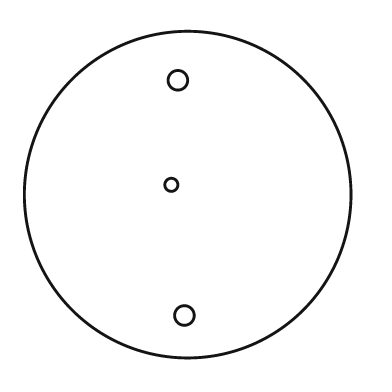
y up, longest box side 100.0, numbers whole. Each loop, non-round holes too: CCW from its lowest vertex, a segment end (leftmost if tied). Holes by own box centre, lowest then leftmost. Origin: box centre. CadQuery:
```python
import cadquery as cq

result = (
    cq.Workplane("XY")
    .moveTo(0.0, 0.0)
    .circle(50.0)
    .moveTo(-1.0, -37.0)
    .circle(3.0)
    .moveTo(-5.0, 3.0)
    .circle(2.0)
    .moveTo(-3.0, 35.0)
    .circle(3.0)
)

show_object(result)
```